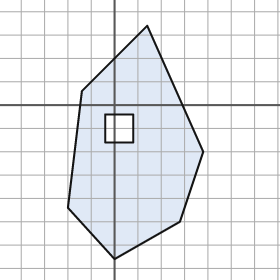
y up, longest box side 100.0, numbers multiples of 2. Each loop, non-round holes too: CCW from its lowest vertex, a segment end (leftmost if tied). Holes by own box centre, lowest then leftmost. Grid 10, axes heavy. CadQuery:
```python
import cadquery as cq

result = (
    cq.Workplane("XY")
    .moveTo(0.0, -66.0)
    .lineTo(28.0, -50.0)
    .lineTo(38.0, -20.0)
    .lineTo(14.0, 34.0)
    .lineTo(-14.0, 6.0)
    .lineTo(-20.0, -44.0)
    .close()
    .moveTo(-4.0, -16.0)
    .lineTo(8.0, -16.0)
    .lineTo(8.0, -4.0)
    .lineTo(-4.0, -4.0)
    .close()
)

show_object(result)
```